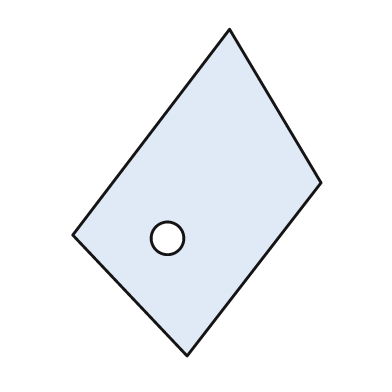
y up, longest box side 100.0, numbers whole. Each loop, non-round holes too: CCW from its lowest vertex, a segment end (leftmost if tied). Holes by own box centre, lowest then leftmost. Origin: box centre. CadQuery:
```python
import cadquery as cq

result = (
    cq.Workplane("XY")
    .moveTo(-3.0, -50.0)
    .lineTo(38.0, 3.0)
    .lineTo(10.0, 50.0)
    .lineTo(-38.0, -13.0)
    .close()
    .moveTo(-9.0, -14.0)
    .circle(5.0)
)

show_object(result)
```